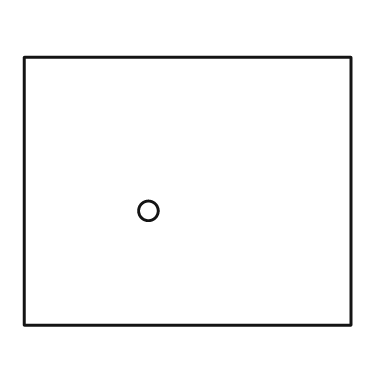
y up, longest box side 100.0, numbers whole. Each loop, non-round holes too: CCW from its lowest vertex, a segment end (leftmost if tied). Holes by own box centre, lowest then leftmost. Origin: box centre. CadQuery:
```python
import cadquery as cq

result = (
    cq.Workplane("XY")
    .moveTo(-50.0, -41.0)
    .lineTo(50.0, -41.0)
    .lineTo(50.0, 41.0)
    .lineTo(-50.0, 41.0)
    .close()
    .moveTo(-12.0, -6.0)
    .circle(3.0)
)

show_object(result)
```